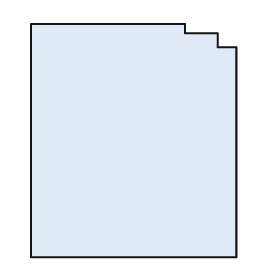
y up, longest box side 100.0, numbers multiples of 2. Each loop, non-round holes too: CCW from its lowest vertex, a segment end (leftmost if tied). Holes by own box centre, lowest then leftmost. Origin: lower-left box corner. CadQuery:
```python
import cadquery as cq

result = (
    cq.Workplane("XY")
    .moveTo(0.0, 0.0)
    .lineTo(88.0, 0.0)
    .lineTo(88.0, 90.0)
    .lineTo(80.0, 90.0)
    .lineTo(80.0, 96.0)
    .lineTo(66.0, 96.0)
    .lineTo(66.0, 100.0)
    .lineTo(0.0, 100.0)
    .close()
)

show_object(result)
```